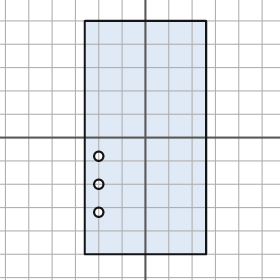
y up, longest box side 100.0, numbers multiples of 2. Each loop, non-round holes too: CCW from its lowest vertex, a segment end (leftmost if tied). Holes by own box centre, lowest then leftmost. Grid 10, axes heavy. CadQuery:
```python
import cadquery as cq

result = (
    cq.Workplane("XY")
    .moveTo(-26.0, -50.0)
    .lineTo(26.0, -50.0)
    .lineTo(26.0, 50.0)
    .lineTo(-26.0, 50.0)
    .close()
    .moveTo(-20.0, -32.0)
    .circle(2.0)
    .moveTo(-20.0, -20.0)
    .circle(2.0)
    .moveTo(-20.0, -8.0)
    .circle(2.0)
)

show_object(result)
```